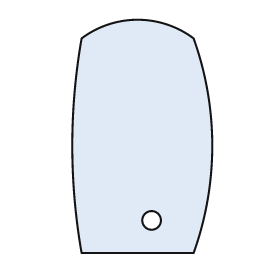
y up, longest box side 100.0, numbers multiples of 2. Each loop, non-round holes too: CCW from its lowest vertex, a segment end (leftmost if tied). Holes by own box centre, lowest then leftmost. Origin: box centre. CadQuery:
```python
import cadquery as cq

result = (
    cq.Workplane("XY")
    .moveTo(-26.0, -50.0)
    .lineTo(22.0, -50.0)
    .threePointArc((30.0, -4.0), (22.0, 42.0))
    .threePointArc((-2.0, 50.0), (-26.0, 42.0))
    .threePointArc((-30.0, -4.0), (-26.0, -50.0))
    .close()
    .moveTo(4.0, -36.0)
    .circle(4.0)
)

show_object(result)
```